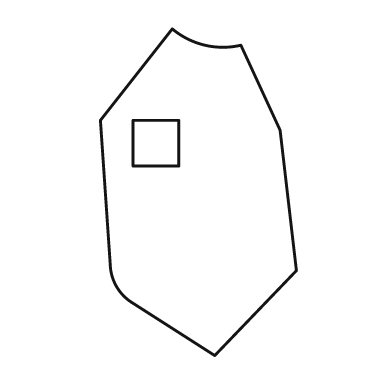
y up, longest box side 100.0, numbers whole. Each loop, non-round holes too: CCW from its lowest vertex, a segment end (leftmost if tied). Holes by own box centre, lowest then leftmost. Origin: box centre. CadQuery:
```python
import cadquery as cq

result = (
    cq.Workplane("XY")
    .moveTo(5.0, -50.0)
    .lineTo(30.0, -24.0)
    .lineTo(25.0, 19.0)
    .lineTo(13.0, 45.0)
    .threePointArc((2.0, 45.0), (-8.0, 50.0))
    .lineTo(-30.0, 22.0)
    .lineTo(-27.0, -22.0)
    .threePointArc((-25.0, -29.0), (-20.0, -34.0))
    .close()
    .moveTo(-20.0, 8.0)
    .lineTo(-6.0, 8.0)
    .lineTo(-6.0, 22.0)
    .lineTo(-20.0, 22.0)
    .close()
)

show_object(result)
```